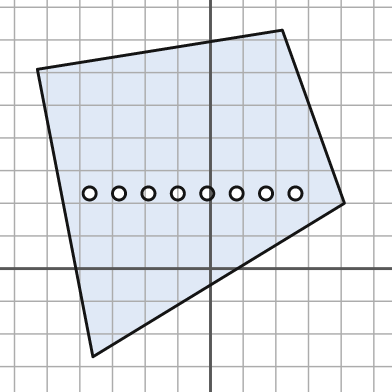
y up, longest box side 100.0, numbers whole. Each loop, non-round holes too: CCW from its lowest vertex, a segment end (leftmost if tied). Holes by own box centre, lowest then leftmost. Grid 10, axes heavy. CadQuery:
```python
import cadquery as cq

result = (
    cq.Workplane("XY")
    .moveTo(-36.0, -27.0)
    .lineTo(41.0, 20.0)
    .lineTo(22.0, 73.0)
    .lineTo(-53.0, 61.0)
    .close()
    .moveTo(-37.0, 23.0)
    .circle(2.0)
    .moveTo(-28.0, 23.0)
    .circle(2.0)
    .moveTo(-19.0, 23.0)
    .circle(2.0)
    .moveTo(-10.0, 23.0)
    .circle(2.0)
    .moveTo(-1.0, 23.0)
    .circle(2.0)
    .moveTo(8.0, 23.0)
    .circle(2.0)
    .moveTo(17.0, 23.0)
    .circle(2.0)
    .moveTo(26.0, 23.0)
    .circle(2.0)
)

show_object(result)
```